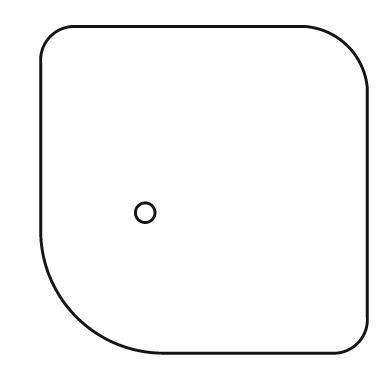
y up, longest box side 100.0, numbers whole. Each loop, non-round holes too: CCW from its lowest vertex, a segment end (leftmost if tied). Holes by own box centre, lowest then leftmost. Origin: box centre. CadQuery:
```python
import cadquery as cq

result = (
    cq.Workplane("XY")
    .moveTo(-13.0, -50.0)
    .lineTo(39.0, -50.0)
    .threePointArc((47.0, -47.0), (50.0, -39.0))
    .lineTo(50.0, 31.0)
    .threePointArc((44.0, 44.0), (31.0, 50.0))
    .lineTo(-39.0, 50.0)
    .threePointArc((-47.0, 47.0), (-50.0, 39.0))
    .lineTo(-50.0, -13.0)
    .threePointArc((-39.0, -39.0), (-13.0, -50.0))
    .close()
    .moveTo(-18.0, -7.0)
    .circle(3.0)
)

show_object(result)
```